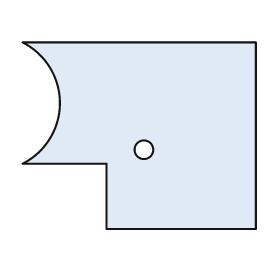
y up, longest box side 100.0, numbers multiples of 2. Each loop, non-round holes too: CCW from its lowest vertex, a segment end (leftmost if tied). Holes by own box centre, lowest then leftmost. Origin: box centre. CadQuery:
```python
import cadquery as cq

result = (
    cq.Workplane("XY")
    .moveTo(-14.0, -40.0)
    .lineTo(50.0, -40.0)
    .lineTo(50.0, 40.0)
    .lineTo(-50.0, 40.0)
    .threePointArc((-34.0, 14.0), (-50.0, -12.0))
    .lineTo(-14.0, -12.0)
    .close()
    .moveTo(2.0, -6.0)
    .circle(4.0)
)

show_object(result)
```